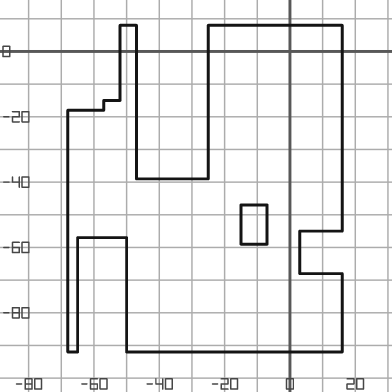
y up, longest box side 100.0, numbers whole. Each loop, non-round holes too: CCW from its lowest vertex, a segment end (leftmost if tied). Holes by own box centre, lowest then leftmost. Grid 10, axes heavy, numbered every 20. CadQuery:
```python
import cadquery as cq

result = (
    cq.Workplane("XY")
    .moveTo(-68.0, -92.0)
    .lineTo(-65.0, -92.0)
    .lineTo(-65.0, -57.0)
    .lineTo(-50.0, -57.0)
    .lineTo(-50.0, -92.0)
    .lineTo(16.0, -92.0)
    .lineTo(16.0, -68.0)
    .lineTo(3.0, -68.0)
    .lineTo(3.0, -55.0)
    .lineTo(16.0, -55.0)
    .lineTo(16.0, 8.0)
    .lineTo(-25.0, 8.0)
    .lineTo(-25.0, -39.0)
    .lineTo(-47.0, -39.0)
    .lineTo(-47.0, 8.0)
    .lineTo(-52.0, 8.0)
    .lineTo(-52.0, -15.0)
    .lineTo(-57.0, -15.0)
    .lineTo(-57.0, -18.0)
    .lineTo(-68.0, -18.0)
    .close()
    .moveTo(-15.0, -59.0)
    .lineTo(-7.0, -59.0)
    .lineTo(-7.0, -47.0)
    .lineTo(-15.0, -47.0)
    .close()
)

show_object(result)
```